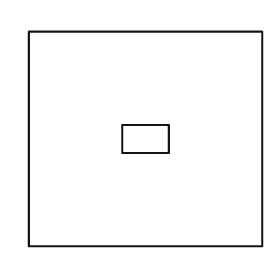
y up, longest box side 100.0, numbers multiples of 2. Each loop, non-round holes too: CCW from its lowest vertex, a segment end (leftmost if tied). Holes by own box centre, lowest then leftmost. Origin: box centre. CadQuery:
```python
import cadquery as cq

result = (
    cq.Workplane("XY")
    .moveTo(-50.0, -46.0)
    .lineTo(50.0, -46.0)
    .lineTo(50.0, 46.0)
    .lineTo(-50.0, 46.0)
    .close()
    .moveTo(-10.0, -6.0)
    .lineTo(10.0, -6.0)
    .lineTo(10.0, 6.0)
    .lineTo(-10.0, 6.0)
    .close()
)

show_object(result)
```